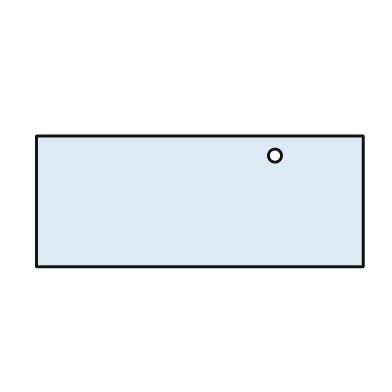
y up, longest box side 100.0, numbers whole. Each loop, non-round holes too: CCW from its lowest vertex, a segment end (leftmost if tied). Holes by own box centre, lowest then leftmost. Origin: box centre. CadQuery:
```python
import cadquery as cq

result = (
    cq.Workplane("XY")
    .moveTo(-50.0, -20.0)
    .lineTo(50.0, -20.0)
    .lineTo(50.0, 20.0)
    .lineTo(-50.0, 20.0)
    .close()
    .moveTo(23.0, 14.0)
    .circle(2.0)
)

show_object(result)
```